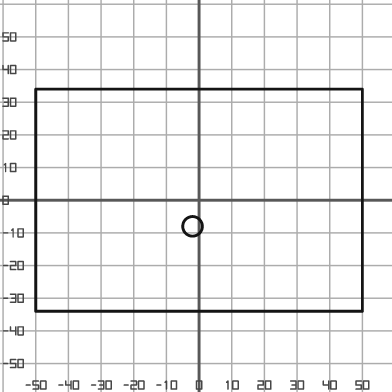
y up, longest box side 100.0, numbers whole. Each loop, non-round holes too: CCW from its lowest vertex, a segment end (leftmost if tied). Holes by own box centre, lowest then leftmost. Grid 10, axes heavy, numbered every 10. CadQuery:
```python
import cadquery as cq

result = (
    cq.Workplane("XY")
    .moveTo(-50.0, -34.0)
    .lineTo(50.0, -34.0)
    .lineTo(50.0, 34.0)
    .lineTo(-50.0, 34.0)
    .close()
    .moveTo(-2.0, -8.0)
    .circle(3.0)
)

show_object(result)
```